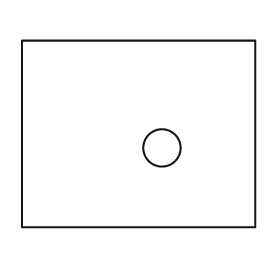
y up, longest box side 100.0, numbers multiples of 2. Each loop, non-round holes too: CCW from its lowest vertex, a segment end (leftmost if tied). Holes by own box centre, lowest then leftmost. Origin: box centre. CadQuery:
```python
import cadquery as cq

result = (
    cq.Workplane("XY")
    .moveTo(-50.0, -40.0)
    .lineTo(50.0, -40.0)
    .lineTo(50.0, 40.0)
    .lineTo(-50.0, 40.0)
    .close()
    .moveTo(10.0, -6.0)
    .circle(8.0)
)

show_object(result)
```